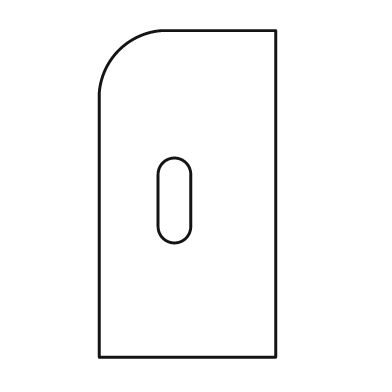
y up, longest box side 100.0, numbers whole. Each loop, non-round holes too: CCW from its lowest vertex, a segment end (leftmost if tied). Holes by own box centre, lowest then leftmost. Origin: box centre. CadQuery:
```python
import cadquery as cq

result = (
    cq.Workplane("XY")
    .moveTo(-27.0, -50.0)
    .lineTo(27.0, -50.0)
    .lineTo(27.0, 50.0)
    .lineTo(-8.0, 50.0)
    .threePointArc((-21.0, 44.0), (-27.0, 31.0))
    .close()
    .moveTo(-9.0, -10.0)
    .threePointArc((-4.0, -15.0), (1.0, -10.0))
    .lineTo(1.0, 6.0)
    .threePointArc((-4.0, 11.0), (-9.0, 6.0))
    .close()
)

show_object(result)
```